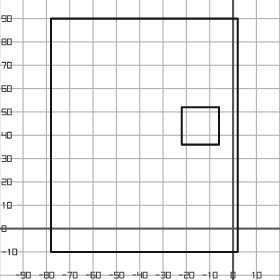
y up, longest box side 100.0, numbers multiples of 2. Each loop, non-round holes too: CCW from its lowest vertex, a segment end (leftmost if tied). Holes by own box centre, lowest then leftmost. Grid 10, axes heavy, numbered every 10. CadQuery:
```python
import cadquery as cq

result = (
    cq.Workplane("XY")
    .moveTo(-78.0, -10.0)
    .lineTo(2.0, -10.0)
    .lineTo(2.0, 90.0)
    .lineTo(-78.0, 90.0)
    .close()
    .moveTo(-22.0, 36.0)
    .lineTo(-6.0, 36.0)
    .lineTo(-6.0, 52.0)
    .lineTo(-22.0, 52.0)
    .close()
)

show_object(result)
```